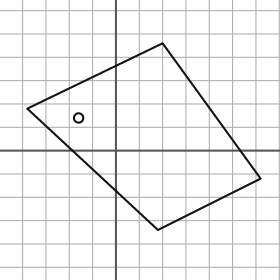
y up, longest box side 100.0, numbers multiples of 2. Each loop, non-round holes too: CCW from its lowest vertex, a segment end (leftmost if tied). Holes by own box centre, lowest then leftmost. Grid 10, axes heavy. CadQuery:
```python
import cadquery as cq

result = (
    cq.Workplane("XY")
    .moveTo(18.0, -34.0)
    .lineTo(62.0, -12.0)
    .lineTo(20.0, 46.0)
    .lineTo(-38.0, 18.0)
    .close()
    .moveTo(-16.0, 14.0)
    .circle(2.0)
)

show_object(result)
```